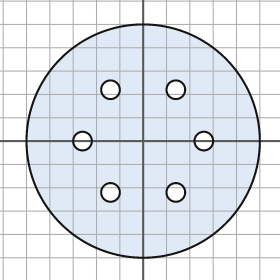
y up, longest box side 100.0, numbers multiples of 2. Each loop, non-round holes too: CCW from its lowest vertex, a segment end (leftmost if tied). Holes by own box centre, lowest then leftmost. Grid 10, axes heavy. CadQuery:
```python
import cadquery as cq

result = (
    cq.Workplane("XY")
    .moveTo(0.0, 0.0)
    .circle(50.0)
    .moveTo(-14.0, -22.0)
    .circle(4.0)
    .moveTo(14.0, -22.0)
    .circle(4.0)
    .moveTo(-26.0, 0.0)
    .circle(4.0)
    .moveTo(26.0, 0.0)
    .circle(4.0)
    .moveTo(-14.0, 22.0)
    .circle(4.0)
    .moveTo(14.0, 22.0)
    .circle(4.0)
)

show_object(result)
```